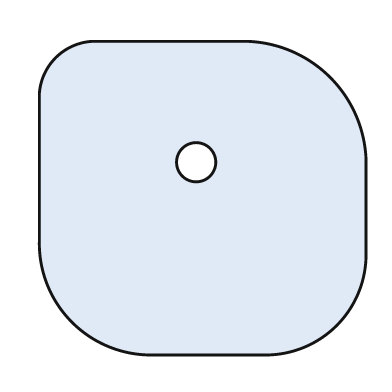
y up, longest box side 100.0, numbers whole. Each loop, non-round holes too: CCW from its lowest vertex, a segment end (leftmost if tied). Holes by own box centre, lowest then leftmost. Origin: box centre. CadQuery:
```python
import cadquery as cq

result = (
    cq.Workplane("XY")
    .moveTo(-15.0, -48.0)
    .lineTo(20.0, -48.0)
    .threePointArc((41.0, -39.0), (50.0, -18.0))
    .lineTo(50.0, 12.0)
    .threePointArc((39.0, 37.0), (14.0, 48.0))
    .lineTo(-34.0, 48.0)
    .threePointArc((-45.0, 43.0), (-50.0, 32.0))
    .lineTo(-50.0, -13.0)
    .threePointArc((-40.0, -38.0), (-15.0, -48.0))
    .close()
    .moveTo(-2.0, 11.0)
    .circle(6.0)
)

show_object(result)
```